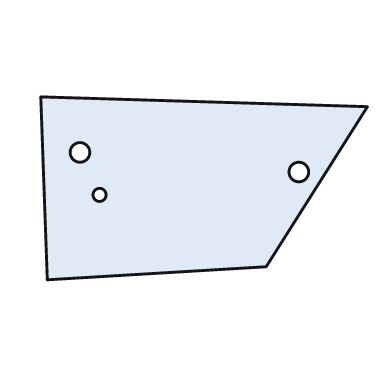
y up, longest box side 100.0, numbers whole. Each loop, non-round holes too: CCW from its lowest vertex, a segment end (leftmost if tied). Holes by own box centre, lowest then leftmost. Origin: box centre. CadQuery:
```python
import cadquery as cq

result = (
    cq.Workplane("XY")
    .moveTo(-48.0, -28.0)
    .lineTo(19.0, -24.0)
    .lineTo(50.0, 25.0)
    .lineTo(-50.0, 28.0)
    .close()
    .moveTo(-32.0, -2.0)
    .circle(2.0)
    .moveTo(29.0, 5.0)
    .circle(3.0)
    .moveTo(-38.0, 11.0)
    .circle(3.0)
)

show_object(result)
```